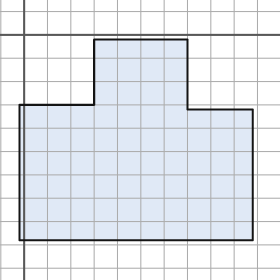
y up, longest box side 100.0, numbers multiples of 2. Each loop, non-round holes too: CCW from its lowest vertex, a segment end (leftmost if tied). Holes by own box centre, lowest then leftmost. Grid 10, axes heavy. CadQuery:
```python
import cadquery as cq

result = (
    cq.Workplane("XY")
    .moveTo(-2.0, -88.0)
    .lineTo(98.0, -88.0)
    .lineTo(98.0, -32.0)
    .lineTo(70.0, -32.0)
    .lineTo(70.0, -2.0)
    .lineTo(30.0, -2.0)
    .lineTo(30.0, -30.0)
    .lineTo(-2.0, -30.0)
    .close()
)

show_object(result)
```